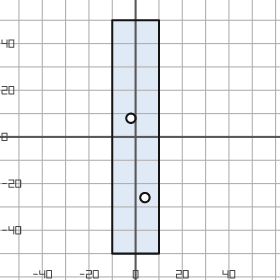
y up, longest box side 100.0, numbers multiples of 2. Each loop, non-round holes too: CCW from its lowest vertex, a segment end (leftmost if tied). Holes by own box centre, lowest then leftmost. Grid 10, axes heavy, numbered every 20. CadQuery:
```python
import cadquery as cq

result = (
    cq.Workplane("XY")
    .moveTo(-10.0, -50.0)
    .lineTo(10.0, -50.0)
    .lineTo(10.0, 50.0)
    .lineTo(-10.0, 50.0)
    .close()
    .moveTo(4.0, -26.0)
    .circle(2.0)
    .moveTo(-2.0, 8.0)
    .circle(2.0)
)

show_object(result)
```